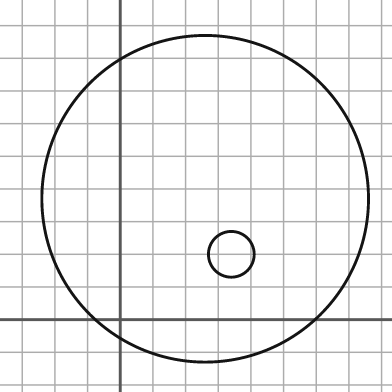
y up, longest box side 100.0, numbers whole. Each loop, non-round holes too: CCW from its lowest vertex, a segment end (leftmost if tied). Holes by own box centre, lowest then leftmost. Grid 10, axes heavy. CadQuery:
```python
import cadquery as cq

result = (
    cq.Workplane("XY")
    .moveTo(26.0, 37.0)
    .circle(50.0)
    .moveTo(34.0, 20.0)
    .circle(7.0)
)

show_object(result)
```